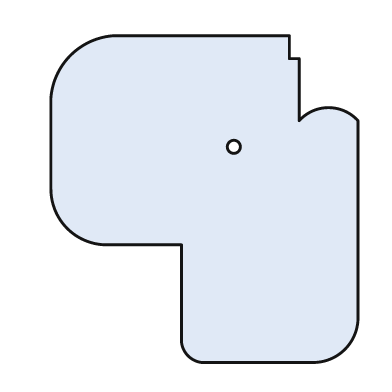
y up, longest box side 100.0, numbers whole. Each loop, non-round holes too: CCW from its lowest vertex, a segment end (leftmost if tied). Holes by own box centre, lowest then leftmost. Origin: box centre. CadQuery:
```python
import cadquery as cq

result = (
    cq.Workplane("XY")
    .moveTo(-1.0, -50.0)
    .lineTo(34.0, -50.0)
    .threePointArc((43.0, -46.0), (47.0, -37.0))
    .lineTo(47.0, 24.0)
    .threePointArc((38.0, 28.0), (29.0, 24.0))
    .lineTo(29.0, 43.0)
    .lineTo(26.0, 43.0)
    .lineTo(26.0, 50.0)
    .lineTo(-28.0, 50.0)
    .threePointArc((-41.0, 44.0), (-47.0, 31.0))
    .lineTo(-47.0, 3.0)
    .threePointArc((-42.0, -9.0), (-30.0, -14.0))
    .lineTo(-7.0, -14.0)
    .lineTo(-7.0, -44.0)
    .threePointArc((-5.0, -48.0), (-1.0, -50.0))
    .close()
    .moveTo(9.0, 16.0)
    .circle(2.0)
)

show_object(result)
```